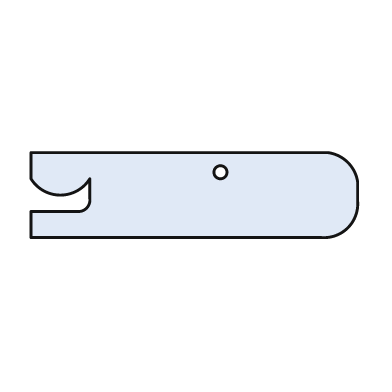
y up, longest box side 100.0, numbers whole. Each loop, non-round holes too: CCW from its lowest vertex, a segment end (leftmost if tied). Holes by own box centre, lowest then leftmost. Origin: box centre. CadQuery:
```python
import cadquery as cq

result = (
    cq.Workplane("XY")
    .moveTo(-50.0, -13.0)
    .lineTo(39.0, -13.0)
    .threePointArc((47.0, -10.0), (50.0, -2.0))
    .lineTo(50.0, 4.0)
    .threePointArc((47.0, 10.0), (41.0, 13.0))
    .lineTo(-50.0, 13.0)
    .lineTo(-50.0, 5.0)
    .threePointArc((-41.0, 0.0), (-32.0, 5.0))
    .lineTo(-32.0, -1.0)
    .threePointArc((-33.0, -4.0), (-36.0, -5.0))
    .lineTo(-50.0, -5.0)
    .close()
    .moveTo(8.0, 7.0)
    .circle(2.0)
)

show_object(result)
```